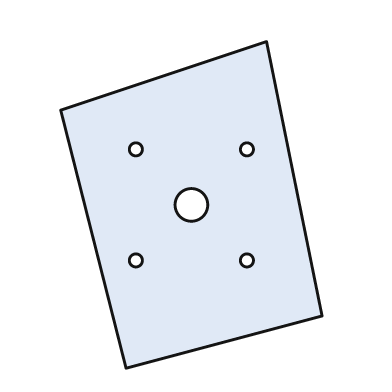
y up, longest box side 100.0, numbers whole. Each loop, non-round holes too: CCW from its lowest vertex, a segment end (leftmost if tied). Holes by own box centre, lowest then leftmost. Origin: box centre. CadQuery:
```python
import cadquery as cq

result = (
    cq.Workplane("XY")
    .moveTo(-20.0, -50.0)
    .lineTo(40.0, -34.0)
    .lineTo(23.0, 50.0)
    .lineTo(-40.0, 29.0)
    .close()
    .moveTo(-17.0, -17.0)
    .circle(2.0)
    .moveTo(17.0, -17.0)
    .circle(2.0)
    .moveTo(0.0, 0.0)
    .circle(5.0)
    .moveTo(-17.0, 17.0)
    .circle(2.0)
    .moveTo(17.0, 17.0)
    .circle(2.0)
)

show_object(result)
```